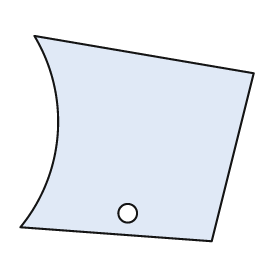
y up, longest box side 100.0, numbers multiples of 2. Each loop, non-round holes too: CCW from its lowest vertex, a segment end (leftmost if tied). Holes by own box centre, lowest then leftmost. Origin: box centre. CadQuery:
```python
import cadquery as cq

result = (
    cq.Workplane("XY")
    .moveTo(32.0, -44.0)
    .lineTo(50.0, 28.0)
    .lineTo(-44.0, 44.0)
    .threePointArc((-34.0, 2.0), (-50.0, -38.0))
    .close()
    .moveTo(-4.0, -32.0)
    .circle(4.0)
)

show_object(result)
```